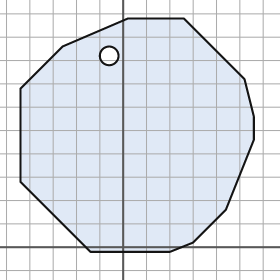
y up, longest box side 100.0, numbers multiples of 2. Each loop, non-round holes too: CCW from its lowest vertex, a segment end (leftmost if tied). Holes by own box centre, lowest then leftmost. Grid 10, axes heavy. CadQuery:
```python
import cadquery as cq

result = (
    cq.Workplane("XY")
    .moveTo(-14.0, -2.0)
    .lineTo(20.0, -2.0)
    .lineTo(30.0, 2.0)
    .lineTo(44.0, 16.0)
    .lineTo(56.0, 46.0)
    .lineTo(56.0, 56.0)
    .lineTo(52.0, 72.0)
    .lineTo(26.0, 98.0)
    .lineTo(2.0, 98.0)
    .lineTo(-26.0, 86.0)
    .lineTo(-44.0, 68.0)
    .lineTo(-44.0, 28.0)
    .close()
    .moveTo(-6.0, 82.0)
    .circle(4.0)
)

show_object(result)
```